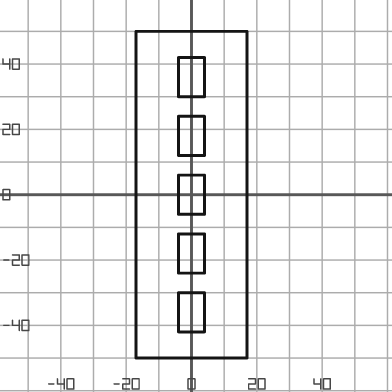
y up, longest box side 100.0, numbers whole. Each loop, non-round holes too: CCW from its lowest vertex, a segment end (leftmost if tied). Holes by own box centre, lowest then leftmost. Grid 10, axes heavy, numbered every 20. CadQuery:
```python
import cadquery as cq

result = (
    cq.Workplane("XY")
    .moveTo(-17.0, -50.0)
    .lineTo(17.0, -50.0)
    .lineTo(17.0, 50.0)
    .lineTo(-17.0, 50.0)
    .close()
    .moveTo(-4.0, -42.0)
    .lineTo(4.0, -42.0)
    .lineTo(4.0, -30.0)
    .lineTo(-4.0, -30.0)
    .close()
    .moveTo(-4.0, -24.0)
    .lineTo(4.0, -24.0)
    .lineTo(4.0, -12.0)
    .lineTo(-4.0, -12.0)
    .close()
    .moveTo(-4.0, -6.0)
    .lineTo(4.0, -6.0)
    .lineTo(4.0, 6.0)
    .lineTo(-4.0, 6.0)
    .close()
    .moveTo(-4.0, 12.0)
    .lineTo(4.0, 12.0)
    .lineTo(4.0, 24.0)
    .lineTo(-4.0, 24.0)
    .close()
    .moveTo(-4.0, 30.0)
    .lineTo(4.0, 30.0)
    .lineTo(4.0, 42.0)
    .lineTo(-4.0, 42.0)
    .close()
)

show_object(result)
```